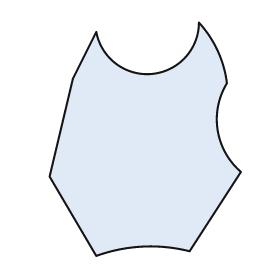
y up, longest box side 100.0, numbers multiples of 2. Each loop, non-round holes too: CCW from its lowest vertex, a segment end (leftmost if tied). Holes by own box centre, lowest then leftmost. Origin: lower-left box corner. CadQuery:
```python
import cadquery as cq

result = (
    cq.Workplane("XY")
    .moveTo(20.0, 0.0)
    .threePointArc((40.0, 4.0), (60.0, 2.0))
    .lineTo(82.0, 36.0)
    .threePointArc((72.0, 54.0), (76.0, 74.0))
    .threePointArc((72.0, 88.0), (64.0, 100.0))
    .threePointArc((44.0, 78.0), (20.0, 96.0))
    .lineTo(10.0, 76.0)
    .lineTo(0.0, 34.0)
    .close()
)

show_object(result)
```